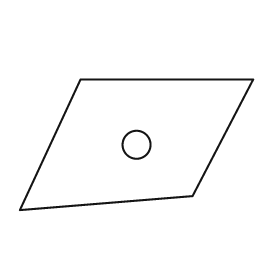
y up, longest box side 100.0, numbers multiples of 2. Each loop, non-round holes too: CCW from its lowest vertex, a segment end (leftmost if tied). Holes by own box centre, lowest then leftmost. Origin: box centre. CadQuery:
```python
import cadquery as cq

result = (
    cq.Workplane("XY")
    .moveTo(-50.0, -28.0)
    .lineTo(24.0, -22.0)
    .lineTo(50.0, 28.0)
    .lineTo(-24.0, 28.0)
    .close()
    .moveTo(0.0, 0.0)
    .circle(6.0)
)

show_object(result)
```